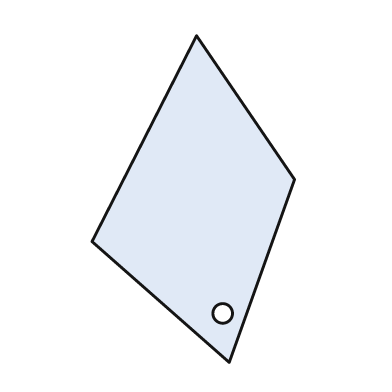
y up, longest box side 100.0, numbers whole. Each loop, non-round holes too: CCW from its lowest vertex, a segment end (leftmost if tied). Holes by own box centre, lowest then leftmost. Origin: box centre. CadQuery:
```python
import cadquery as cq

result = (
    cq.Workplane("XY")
    .moveTo(11.0, -50.0)
    .lineTo(31.0, 6.0)
    .lineTo(1.0, 50.0)
    .lineTo(-31.0, -13.0)
    .close()
    .moveTo(9.0, -35.0)
    .circle(3.0)
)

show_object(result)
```